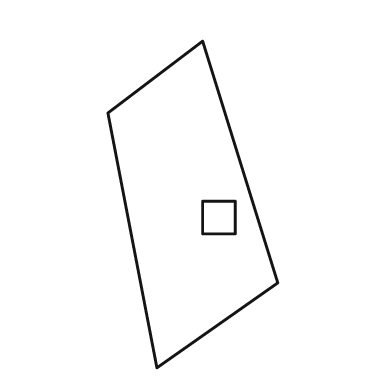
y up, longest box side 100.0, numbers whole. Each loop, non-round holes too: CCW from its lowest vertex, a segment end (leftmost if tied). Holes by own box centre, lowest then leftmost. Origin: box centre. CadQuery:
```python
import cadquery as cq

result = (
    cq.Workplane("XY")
    .moveTo(-11.0, -50.0)
    .lineTo(26.0, -24.0)
    .lineTo(3.0, 50.0)
    .lineTo(-26.0, 28.0)
    .close()
    .moveTo(3.0, -9.0)
    .lineTo(13.0, -9.0)
    .lineTo(13.0, 1.0)
    .lineTo(3.0, 1.0)
    .close()
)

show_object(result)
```